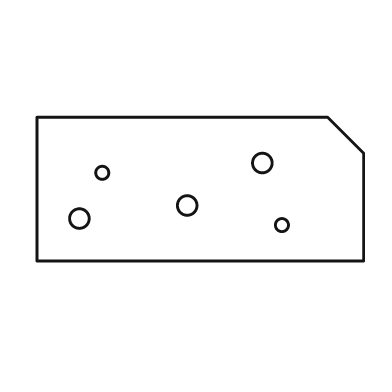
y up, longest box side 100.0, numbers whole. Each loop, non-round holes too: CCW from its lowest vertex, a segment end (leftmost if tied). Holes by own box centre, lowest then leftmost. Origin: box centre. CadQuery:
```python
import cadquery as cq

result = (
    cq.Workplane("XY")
    .moveTo(-50.0, -22.0)
    .lineTo(50.0, -22.0)
    .lineTo(50.0, 11.0)
    .lineTo(39.0, 22.0)
    .lineTo(-50.0, 22.0)
    .close()
    .moveTo(25.0, -11.0)
    .circle(2.0)
    .moveTo(-37.0, -9.0)
    .circle(3.0)
    .moveTo(-4.0, -5.0)
    .circle(3.0)
    .moveTo(-30.0, 5.0)
    .circle(2.0)
    .moveTo(19.0, 8.0)
    .circle(3.0)
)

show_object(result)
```